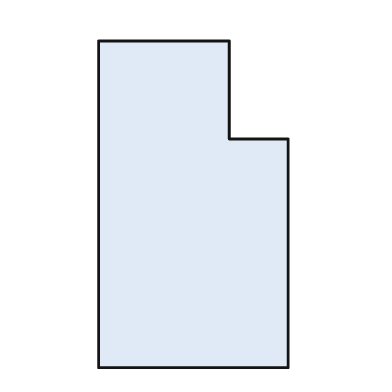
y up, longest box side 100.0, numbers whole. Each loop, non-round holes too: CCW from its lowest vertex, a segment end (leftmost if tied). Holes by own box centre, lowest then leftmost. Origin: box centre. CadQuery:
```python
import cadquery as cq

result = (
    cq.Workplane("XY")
    .moveTo(-29.0, -50.0)
    .lineTo(29.0, -50.0)
    .lineTo(29.0, 20.0)
    .lineTo(11.0, 20.0)
    .lineTo(11.0, 50.0)
    .lineTo(-29.0, 50.0)
    .close()
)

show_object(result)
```